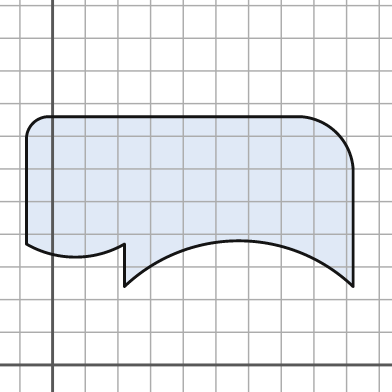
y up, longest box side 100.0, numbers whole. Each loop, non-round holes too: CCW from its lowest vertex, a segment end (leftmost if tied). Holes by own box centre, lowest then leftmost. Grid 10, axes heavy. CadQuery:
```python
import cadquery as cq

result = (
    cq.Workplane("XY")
    .moveTo(22.0, 24.0)
    .threePointArc((57.0, 38.0), (92.0, 24.0))
    .lineTo(92.0, 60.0)
    .threePointArc((87.0, 71.0), (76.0, 76.0))
    .lineTo(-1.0, 76.0)
    .threePointArc((-6.0, 74.0), (-8.0, 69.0))
    .lineTo(-8.0, 37.0)
    .threePointArc((7.0, 33.0), (22.0, 37.0))
    .close()
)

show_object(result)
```